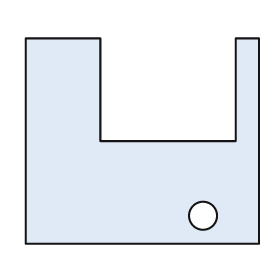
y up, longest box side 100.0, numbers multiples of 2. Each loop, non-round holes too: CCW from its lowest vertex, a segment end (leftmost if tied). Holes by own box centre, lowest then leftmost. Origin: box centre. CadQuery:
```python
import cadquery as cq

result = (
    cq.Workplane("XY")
    .moveTo(-50.0, -44.0)
    .lineTo(50.0, -44.0)
    .lineTo(50.0, 44.0)
    .lineTo(40.0, 44.0)
    .lineTo(40.0, 0.0)
    .lineTo(-18.0, 0.0)
    .lineTo(-18.0, 44.0)
    .lineTo(-50.0, 44.0)
    .close()
    .moveTo(26.0, -32.0)
    .circle(6.0)
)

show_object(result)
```